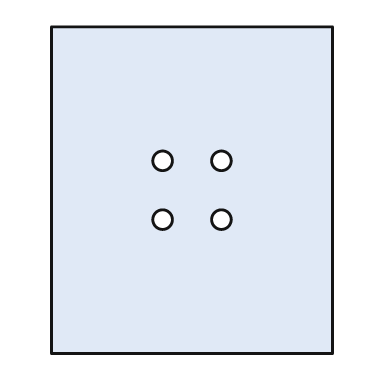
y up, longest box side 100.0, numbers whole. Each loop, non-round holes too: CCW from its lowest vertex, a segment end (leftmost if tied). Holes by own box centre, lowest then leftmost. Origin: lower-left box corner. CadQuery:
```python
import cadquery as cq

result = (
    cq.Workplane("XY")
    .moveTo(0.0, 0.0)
    .lineTo(86.0, 0.0)
    .lineTo(86.0, 100.0)
    .lineTo(0.0, 100.0)
    .close()
    .moveTo(34.0, 41.0)
    .circle(3.0)
    .moveTo(52.0, 41.0)
    .circle(3.0)
    .moveTo(34.0, 59.0)
    .circle(3.0)
    .moveTo(52.0, 59.0)
    .circle(3.0)
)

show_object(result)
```